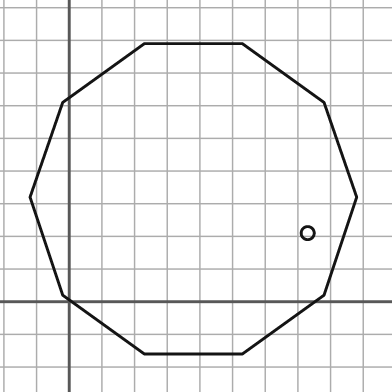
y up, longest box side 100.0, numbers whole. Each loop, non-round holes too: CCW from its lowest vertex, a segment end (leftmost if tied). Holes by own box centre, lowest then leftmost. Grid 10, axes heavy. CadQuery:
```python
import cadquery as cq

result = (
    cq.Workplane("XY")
    .moveTo(23.0, -16.0)
    .lineTo(53.0, -16.0)
    .lineTo(78.0, 2.0)
    .lineTo(88.0, 32.0)
    .lineTo(78.0, 61.0)
    .lineTo(53.0, 79.0)
    .lineTo(23.0, 79.0)
    .lineTo(-2.0, 61.0)
    .lineTo(-12.0, 32.0)
    .lineTo(-2.0, 2.0)
    .close()
    .moveTo(73.0, 21.0)
    .circle(2.0)
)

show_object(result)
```